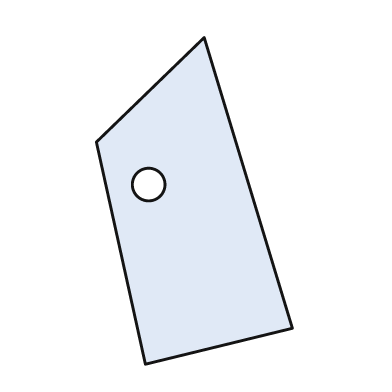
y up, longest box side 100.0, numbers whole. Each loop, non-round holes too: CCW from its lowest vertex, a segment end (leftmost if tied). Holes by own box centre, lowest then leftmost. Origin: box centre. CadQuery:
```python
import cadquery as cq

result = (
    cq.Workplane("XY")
    .moveTo(-15.0, -50.0)
    .lineTo(30.0, -39.0)
    .lineTo(3.0, 50.0)
    .lineTo(-30.0, 18.0)
    .close()
    .moveTo(-14.0, 5.0)
    .circle(5.0)
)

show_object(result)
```